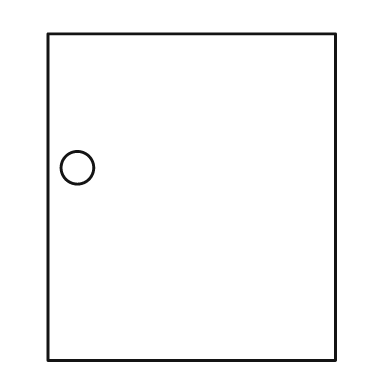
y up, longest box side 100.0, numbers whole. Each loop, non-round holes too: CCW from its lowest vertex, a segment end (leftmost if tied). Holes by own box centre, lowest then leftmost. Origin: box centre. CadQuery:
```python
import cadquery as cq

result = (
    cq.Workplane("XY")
    .moveTo(-44.0, -50.0)
    .lineTo(44.0, -50.0)
    .lineTo(44.0, 50.0)
    .lineTo(-44.0, 50.0)
    .close()
    .moveTo(-35.0, 9.0)
    .circle(5.0)
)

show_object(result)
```